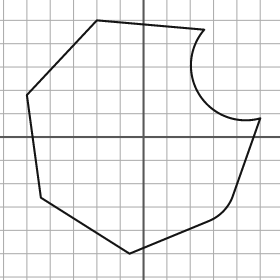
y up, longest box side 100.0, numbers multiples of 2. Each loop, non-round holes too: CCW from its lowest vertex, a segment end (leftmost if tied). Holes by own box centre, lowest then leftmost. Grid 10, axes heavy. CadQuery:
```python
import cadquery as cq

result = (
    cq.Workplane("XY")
    .moveTo(-6.0, -50.0)
    .lineTo(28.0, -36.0)
    .threePointArc((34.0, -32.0), (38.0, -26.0))
    .lineTo(50.0, 8.0)
    .threePointArc((24.0, 18.0), (26.0, 46.0))
    .lineTo(-20.0, 50.0)
    .lineTo(-50.0, 18.0)
    .lineTo(-44.0, -26.0)
    .close()
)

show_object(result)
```